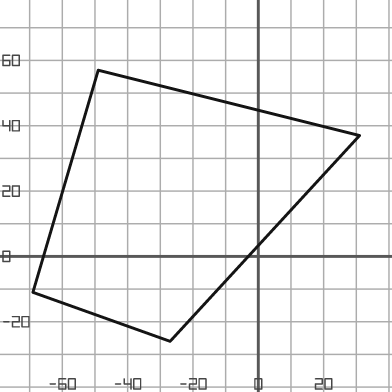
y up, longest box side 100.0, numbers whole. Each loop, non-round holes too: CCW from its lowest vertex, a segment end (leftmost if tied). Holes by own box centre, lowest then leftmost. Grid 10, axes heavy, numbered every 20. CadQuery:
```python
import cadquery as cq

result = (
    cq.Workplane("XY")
    .moveTo(-27.0, -26.0)
    .lineTo(31.0, 37.0)
    .lineTo(-49.0, 57.0)
    .lineTo(-69.0, -11.0)
    .close()
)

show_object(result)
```